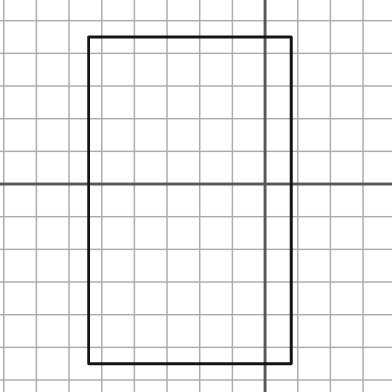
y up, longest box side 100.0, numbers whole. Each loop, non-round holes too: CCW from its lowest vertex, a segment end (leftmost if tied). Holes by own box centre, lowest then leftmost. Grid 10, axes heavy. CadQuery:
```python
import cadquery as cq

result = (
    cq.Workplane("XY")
    .moveTo(-54.0, -55.0)
    .lineTo(8.0, -55.0)
    .lineTo(8.0, 45.0)
    .lineTo(-54.0, 45.0)
    .close()
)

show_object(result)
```